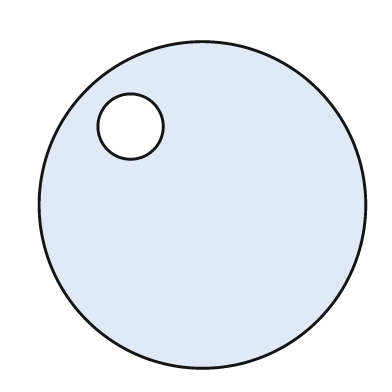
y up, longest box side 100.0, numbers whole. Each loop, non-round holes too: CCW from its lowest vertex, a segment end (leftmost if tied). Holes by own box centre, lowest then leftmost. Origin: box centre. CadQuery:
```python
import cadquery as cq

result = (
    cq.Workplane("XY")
    .moveTo(0.0, 0.0)
    .circle(50.0)
    .moveTo(-22.0, 24.0)
    .circle(10.0)
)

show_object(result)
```